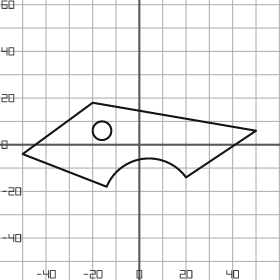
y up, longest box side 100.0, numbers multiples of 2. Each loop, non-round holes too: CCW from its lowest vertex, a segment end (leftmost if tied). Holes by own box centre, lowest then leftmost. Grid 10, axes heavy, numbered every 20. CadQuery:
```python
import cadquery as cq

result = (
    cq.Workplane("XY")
    .moveTo(-14.0, -18.0)
    .threePointArc((2.0, -6.0), (20.0, -14.0))
    .lineTo(50.0, 6.0)
    .lineTo(-20.0, 18.0)
    .lineTo(-50.0, -4.0)
    .close()
    .moveTo(-16.0, 6.0)
    .circle(4.0)
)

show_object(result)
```